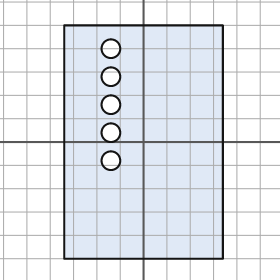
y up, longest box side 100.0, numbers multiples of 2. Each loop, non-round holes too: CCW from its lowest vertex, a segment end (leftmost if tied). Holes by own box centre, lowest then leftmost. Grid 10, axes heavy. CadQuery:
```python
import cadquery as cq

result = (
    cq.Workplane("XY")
    .moveTo(-34.0, -50.0)
    .lineTo(34.0, -50.0)
    .lineTo(34.0, 50.0)
    .lineTo(-34.0, 50.0)
    .close()
    .moveTo(-14.0, -8.0)
    .circle(4.0)
    .moveTo(-14.0, 4.0)
    .circle(4.0)
    .moveTo(-14.0, 16.0)
    .circle(4.0)
    .moveTo(-14.0, 28.0)
    .circle(4.0)
    .moveTo(-14.0, 40.0)
    .circle(4.0)
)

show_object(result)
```